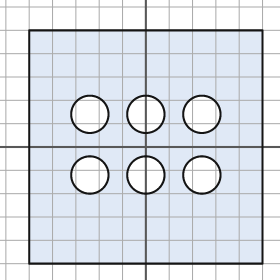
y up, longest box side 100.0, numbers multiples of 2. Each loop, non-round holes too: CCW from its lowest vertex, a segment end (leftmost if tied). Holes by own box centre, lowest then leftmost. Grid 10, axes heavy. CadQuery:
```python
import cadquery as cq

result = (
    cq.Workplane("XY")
    .moveTo(-50.0, -50.0)
    .lineTo(50.0, -50.0)
    .lineTo(50.0, 50.0)
    .lineTo(-50.0, 50.0)
    .close()
    .moveTo(-24.0, -12.0)
    .circle(8.0)
    .moveTo(0.0, -12.0)
    .circle(8.0)
    .moveTo(24.0, -12.0)
    .circle(8.0)
    .moveTo(-24.0, 14.0)
    .circle(8.0)
    .moveTo(0.0, 14.0)
    .circle(8.0)
    .moveTo(24.0, 14.0)
    .circle(8.0)
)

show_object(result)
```